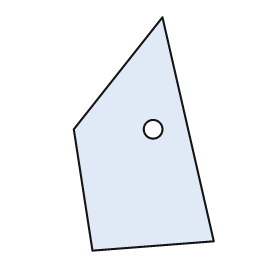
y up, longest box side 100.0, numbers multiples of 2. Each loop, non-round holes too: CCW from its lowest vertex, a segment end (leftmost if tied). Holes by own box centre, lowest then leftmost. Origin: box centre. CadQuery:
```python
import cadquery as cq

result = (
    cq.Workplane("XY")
    .moveTo(-22.0, -50.0)
    .lineTo(30.0, -46.0)
    .lineTo(8.0, 50.0)
    .lineTo(-30.0, 2.0)
    .close()
    .moveTo(4.0, 2.0)
    .circle(4.0)
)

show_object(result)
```